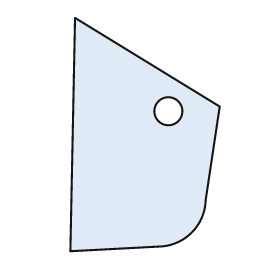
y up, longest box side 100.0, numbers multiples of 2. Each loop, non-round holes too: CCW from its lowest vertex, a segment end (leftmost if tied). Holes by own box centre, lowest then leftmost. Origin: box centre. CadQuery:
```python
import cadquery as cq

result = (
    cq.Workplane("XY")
    .moveTo(-32.0, -50.0)
    .lineTo(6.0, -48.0)
    .threePointArc((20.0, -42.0), (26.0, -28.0))
    .lineTo(32.0, 12.0)
    .lineTo(-30.0, 50.0)
    .close()
    .moveTo(10.0, 10.0)
    .circle(6.0)
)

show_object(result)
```